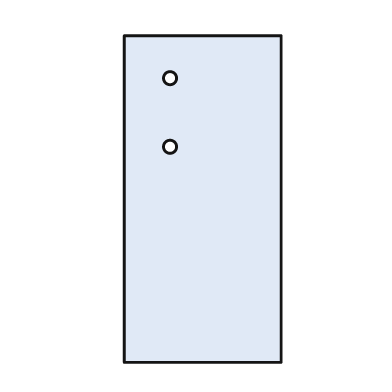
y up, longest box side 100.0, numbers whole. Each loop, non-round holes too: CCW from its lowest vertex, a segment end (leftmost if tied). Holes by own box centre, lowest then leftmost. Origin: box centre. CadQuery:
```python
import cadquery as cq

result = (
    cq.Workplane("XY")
    .moveTo(-24.0, -50.0)
    .lineTo(24.0, -50.0)
    .lineTo(24.0, 50.0)
    .lineTo(-24.0, 50.0)
    .close()
    .moveTo(-10.0, 16.0)
    .circle(2.0)
    .moveTo(-10.0, 37.0)
    .circle(2.0)
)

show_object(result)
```